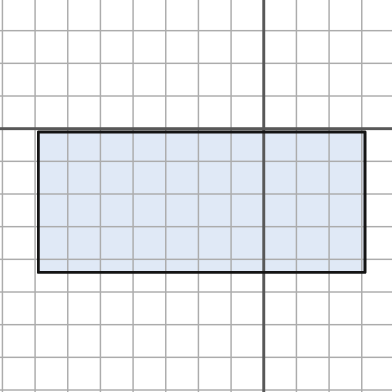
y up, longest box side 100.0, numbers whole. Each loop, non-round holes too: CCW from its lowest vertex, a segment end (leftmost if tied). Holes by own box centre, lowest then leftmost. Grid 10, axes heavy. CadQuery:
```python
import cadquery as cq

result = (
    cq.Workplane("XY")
    .moveTo(-69.0, -44.0)
    .lineTo(31.0, -44.0)
    .lineTo(31.0, -1.0)
    .lineTo(-69.0, -1.0)
    .close()
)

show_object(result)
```